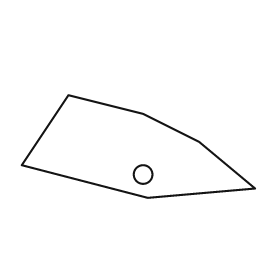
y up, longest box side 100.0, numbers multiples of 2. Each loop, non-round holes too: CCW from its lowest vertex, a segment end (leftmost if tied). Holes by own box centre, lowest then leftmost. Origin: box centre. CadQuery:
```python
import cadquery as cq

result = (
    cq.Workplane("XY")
    .moveTo(4.0, -22.0)
    .lineTo(50.0, -18.0)
    .lineTo(26.0, 2.0)
    .lineTo(2.0, 14.0)
    .lineTo(-30.0, 22.0)
    .lineTo(-50.0, -8.0)
    .close()
    .moveTo(2.0, -12.0)
    .circle(4.0)
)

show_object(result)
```